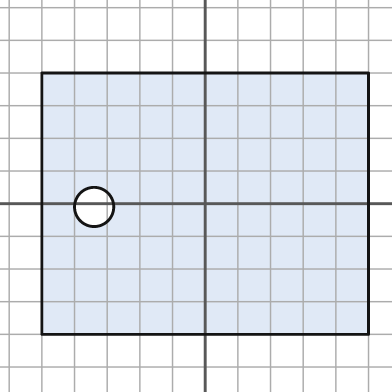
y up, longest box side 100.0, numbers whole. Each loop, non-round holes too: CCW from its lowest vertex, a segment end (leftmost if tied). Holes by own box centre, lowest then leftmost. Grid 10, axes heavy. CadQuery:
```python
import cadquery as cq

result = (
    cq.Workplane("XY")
    .moveTo(-50.0, -40.0)
    .lineTo(50.0, -40.0)
    .lineTo(50.0, 40.0)
    .lineTo(-50.0, 40.0)
    .close()
    .moveTo(-34.0, -1.0)
    .circle(6.0)
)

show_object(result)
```